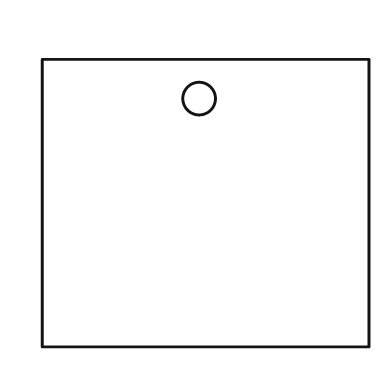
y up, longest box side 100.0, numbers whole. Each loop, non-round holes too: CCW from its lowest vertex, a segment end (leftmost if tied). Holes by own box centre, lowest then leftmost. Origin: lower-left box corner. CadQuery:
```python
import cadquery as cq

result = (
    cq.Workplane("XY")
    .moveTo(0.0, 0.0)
    .lineTo(100.0, 0.0)
    .lineTo(100.0, 88.0)
    .lineTo(0.0, 88.0)
    .close()
    .moveTo(48.0, 76.0)
    .circle(5.0)
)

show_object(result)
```